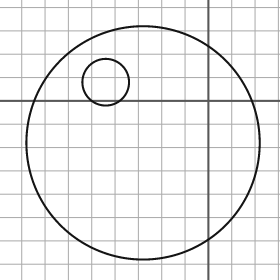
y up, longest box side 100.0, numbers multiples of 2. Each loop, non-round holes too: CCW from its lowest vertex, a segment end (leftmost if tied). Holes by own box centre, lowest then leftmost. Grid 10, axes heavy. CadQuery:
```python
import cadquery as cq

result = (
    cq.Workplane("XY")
    .moveTo(-28.0, -18.0)
    .circle(50.0)
    .moveTo(-44.0, 8.0)
    .circle(10.0)
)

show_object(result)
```